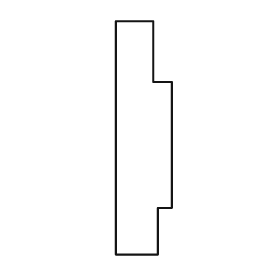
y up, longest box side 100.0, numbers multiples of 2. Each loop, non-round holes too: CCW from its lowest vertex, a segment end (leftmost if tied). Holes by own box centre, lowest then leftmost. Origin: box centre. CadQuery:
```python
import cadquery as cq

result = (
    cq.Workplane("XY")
    .moveTo(-12.0, -50.0)
    .lineTo(6.0, -50.0)
    .lineTo(6.0, -30.0)
    .lineTo(12.0, -30.0)
    .lineTo(12.0, 24.0)
    .lineTo(4.0, 24.0)
    .lineTo(4.0, 50.0)
    .lineTo(-12.0, 50.0)
    .close()
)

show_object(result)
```